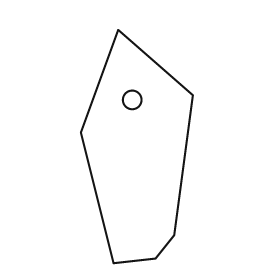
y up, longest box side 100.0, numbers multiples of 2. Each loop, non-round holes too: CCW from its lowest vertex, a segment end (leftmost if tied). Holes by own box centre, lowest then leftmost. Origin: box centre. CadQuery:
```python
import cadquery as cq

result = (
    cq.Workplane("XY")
    .moveTo(-10.0, -50.0)
    .lineTo(8.0, -48.0)
    .lineTo(16.0, -38.0)
    .lineTo(24.0, 22.0)
    .lineTo(-8.0, 50.0)
    .lineTo(-24.0, 6.0)
    .close()
    .moveTo(-2.0, 20.0)
    .circle(4.0)
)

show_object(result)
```